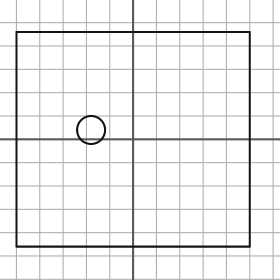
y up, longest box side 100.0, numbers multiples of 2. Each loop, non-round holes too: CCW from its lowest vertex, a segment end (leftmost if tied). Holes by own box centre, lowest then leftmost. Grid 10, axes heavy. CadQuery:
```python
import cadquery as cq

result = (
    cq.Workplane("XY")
    .moveTo(-50.0, -46.0)
    .lineTo(50.0, -46.0)
    .lineTo(50.0, 46.0)
    .lineTo(-50.0, 46.0)
    .close()
    .moveTo(-18.0, 4.0)
    .circle(6.0)
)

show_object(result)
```